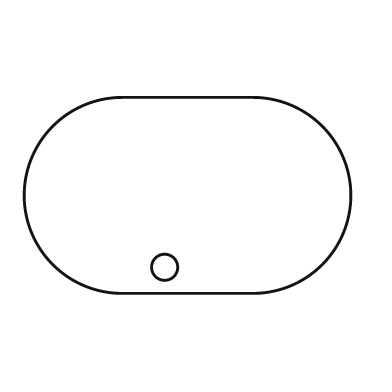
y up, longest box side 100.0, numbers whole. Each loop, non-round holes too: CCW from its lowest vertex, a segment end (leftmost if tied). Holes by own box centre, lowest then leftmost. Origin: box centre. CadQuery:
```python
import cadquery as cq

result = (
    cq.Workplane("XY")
    .moveTo(-20.0, -30.0)
    .lineTo(20.0, -30.0)
    .threePointArc((50.0, 0.0), (20.0, 30.0))
    .lineTo(-20.0, 30.0)
    .threePointArc((-50.0, 0.0), (-20.0, -30.0))
    .close()
    .moveTo(-7.0, -22.0)
    .circle(4.0)
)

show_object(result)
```